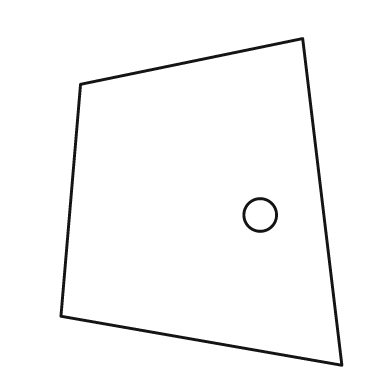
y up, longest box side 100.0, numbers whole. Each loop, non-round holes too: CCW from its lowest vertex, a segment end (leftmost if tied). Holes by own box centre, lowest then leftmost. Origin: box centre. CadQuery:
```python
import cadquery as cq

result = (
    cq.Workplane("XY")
    .moveTo(43.0, -50.0)
    .lineTo(31.0, 50.0)
    .lineTo(-37.0, 36.0)
    .lineTo(-43.0, -35.0)
    .close()
    .moveTo(18.0, -4.0)
    .circle(5.0)
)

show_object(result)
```